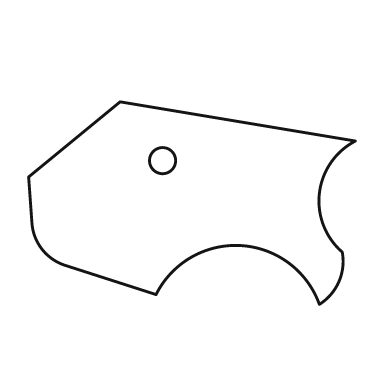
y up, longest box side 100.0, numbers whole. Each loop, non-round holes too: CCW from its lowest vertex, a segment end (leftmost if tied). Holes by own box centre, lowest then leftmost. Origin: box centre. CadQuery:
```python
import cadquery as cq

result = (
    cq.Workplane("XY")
    .moveTo(39.0, -31.0)
    .threePointArc((45.0, -24.0), (46.0, -15.0))
    .threePointArc((39.0, 3.0), (50.0, 19.0))
    .lineTo(-22.0, 31.0)
    .lineTo(-50.0, 8.0)
    .lineTo(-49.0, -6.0)
    .threePointArc((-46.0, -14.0), (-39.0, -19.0))
    .lineTo(-11.0, -28.0)
    .threePointArc((15.0, -13.0), (39.0, -31.0))
    .close()
    .moveTo(-9.0, 13.0)
    .circle(4.0)
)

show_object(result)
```